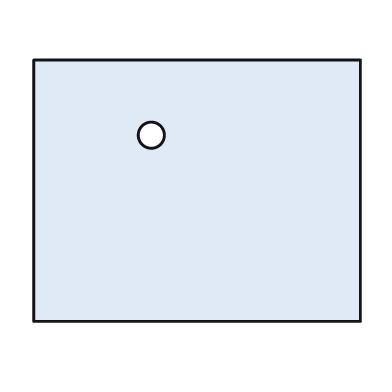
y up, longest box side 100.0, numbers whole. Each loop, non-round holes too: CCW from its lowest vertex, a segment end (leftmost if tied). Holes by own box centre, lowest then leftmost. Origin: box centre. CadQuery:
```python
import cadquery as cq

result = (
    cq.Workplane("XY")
    .moveTo(-50.0, -40.0)
    .lineTo(50.0, -40.0)
    .lineTo(50.0, 40.0)
    .lineTo(-50.0, 40.0)
    .close()
    .moveTo(-14.0, 17.0)
    .circle(4.0)
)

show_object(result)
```